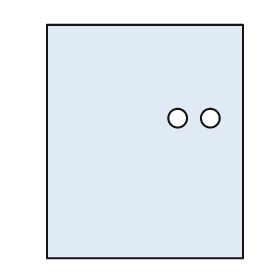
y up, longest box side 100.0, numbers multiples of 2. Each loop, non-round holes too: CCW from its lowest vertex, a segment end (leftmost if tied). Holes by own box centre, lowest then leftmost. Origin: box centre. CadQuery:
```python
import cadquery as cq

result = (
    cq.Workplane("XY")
    .moveTo(-42.0, -50.0)
    .lineTo(42.0, -50.0)
    .lineTo(42.0, 50.0)
    .lineTo(-42.0, 50.0)
    .close()
    .moveTo(14.0, 10.0)
    .circle(4.0)
    .moveTo(28.0, 10.0)
    .circle(4.0)
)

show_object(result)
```